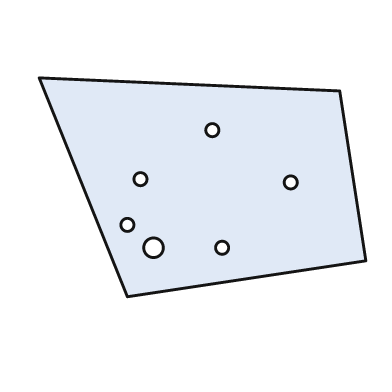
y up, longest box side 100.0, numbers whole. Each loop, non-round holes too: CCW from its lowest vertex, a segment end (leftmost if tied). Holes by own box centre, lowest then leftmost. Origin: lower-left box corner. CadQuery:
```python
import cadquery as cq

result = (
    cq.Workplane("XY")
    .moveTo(27.0, 0.0)
    .lineTo(100.0, 11.0)
    .lineTo(92.0, 63.0)
    .lineTo(0.0, 67.0)
    .close()
    .moveTo(35.0, 15.0)
    .circle(3.0)
    .moveTo(56.0, 15.0)
    .circle(2.0)
    .moveTo(27.0, 22.0)
    .circle(2.0)
    .moveTo(77.0, 35.0)
    .circle(2.0)
    .moveTo(31.0, 36.0)
    .circle(2.0)
    .moveTo(53.0, 51.0)
    .circle(2.0)
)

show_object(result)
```